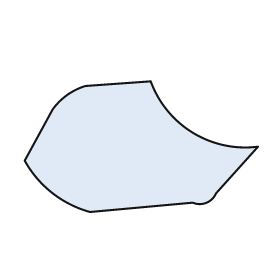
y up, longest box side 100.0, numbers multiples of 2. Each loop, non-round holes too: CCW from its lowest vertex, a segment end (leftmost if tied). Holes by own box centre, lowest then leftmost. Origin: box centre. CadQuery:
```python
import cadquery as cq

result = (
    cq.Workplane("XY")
    .moveTo(-22.0, -28.0)
    .lineTo(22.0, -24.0)
    .threePointArc((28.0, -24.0), (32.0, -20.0))
    .lineTo(50.0, 0.0)
    .threePointArc((22.0, 6.0), (4.0, 28.0))
    .lineTo(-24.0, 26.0)
    .threePointArc((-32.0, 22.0), (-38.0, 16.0))
    .lineTo(-50.0, -6.0)
    .threePointArc((-38.0, -20.0), (-22.0, -28.0))
    .close()
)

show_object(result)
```